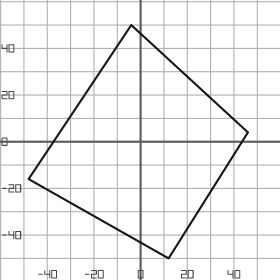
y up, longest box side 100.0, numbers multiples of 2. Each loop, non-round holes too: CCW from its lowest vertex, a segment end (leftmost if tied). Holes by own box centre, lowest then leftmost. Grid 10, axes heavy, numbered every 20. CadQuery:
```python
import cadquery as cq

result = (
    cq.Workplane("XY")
    .moveTo(12.0, -50.0)
    .lineTo(46.0, 4.0)
    .lineTo(-4.0, 50.0)
    .lineTo(-48.0, -16.0)
    .close()
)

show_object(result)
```